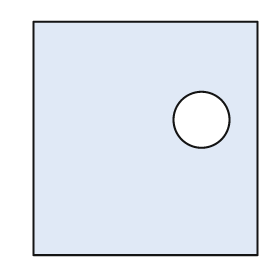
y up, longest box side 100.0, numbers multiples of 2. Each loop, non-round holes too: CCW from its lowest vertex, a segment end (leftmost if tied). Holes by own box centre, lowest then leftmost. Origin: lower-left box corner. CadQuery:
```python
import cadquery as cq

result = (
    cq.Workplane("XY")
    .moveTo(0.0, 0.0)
    .lineTo(96.0, 0.0)
    .lineTo(96.0, 100.0)
    .lineTo(0.0, 100.0)
    .close()
    .moveTo(72.0, 58.0)
    .circle(12.0)
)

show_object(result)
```